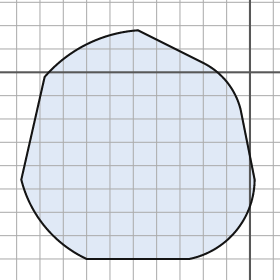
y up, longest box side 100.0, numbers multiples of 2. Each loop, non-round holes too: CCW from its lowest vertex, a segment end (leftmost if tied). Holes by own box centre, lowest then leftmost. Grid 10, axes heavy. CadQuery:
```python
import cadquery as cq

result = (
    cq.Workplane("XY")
    .moveTo(-70.0, -80.0)
    .lineTo(-26.0, -80.0)
    .threePointArc((-6.0, -68.0), (2.0, -46.0))
    .lineTo(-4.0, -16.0)
    .threePointArc((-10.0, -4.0), (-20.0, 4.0))
    .lineTo(-48.0, 18.0)
    .threePointArc((-70.0, 12.0), (-88.0, -2.0))
    .lineTo(-98.0, -46.0)
    .threePointArc((-88.0, -66.0), (-70.0, -80.0))
    .close()
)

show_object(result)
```